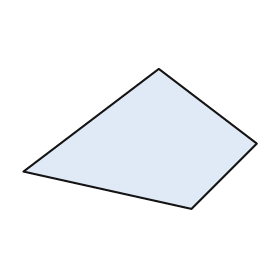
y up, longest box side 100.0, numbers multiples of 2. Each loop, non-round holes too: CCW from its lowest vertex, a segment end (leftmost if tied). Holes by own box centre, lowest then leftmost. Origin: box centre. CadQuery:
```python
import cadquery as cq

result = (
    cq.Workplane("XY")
    .moveTo(22.0, -30.0)
    .lineTo(50.0, -2.0)
    .lineTo(8.0, 30.0)
    .lineTo(-50.0, -14.0)
    .close()
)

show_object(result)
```